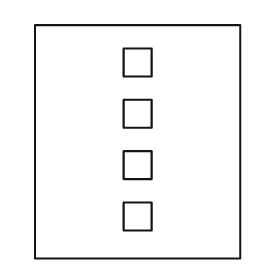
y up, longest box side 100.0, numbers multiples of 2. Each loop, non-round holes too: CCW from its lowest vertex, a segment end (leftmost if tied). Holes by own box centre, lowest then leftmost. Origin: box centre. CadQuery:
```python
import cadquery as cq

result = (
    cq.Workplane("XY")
    .moveTo(-44.0, -50.0)
    .lineTo(44.0, -50.0)
    .lineTo(44.0, 50.0)
    .lineTo(-44.0, 50.0)
    .close()
    .moveTo(-6.0, -38.0)
    .lineTo(6.0, -38.0)
    .lineTo(6.0, -26.0)
    .lineTo(-6.0, -26.0)
    .close()
    .moveTo(-6.0, -16.0)
    .lineTo(6.0, -16.0)
    .lineTo(6.0, -4.0)
    .lineTo(-6.0, -4.0)
    .close()
    .moveTo(-6.0, 6.0)
    .lineTo(6.0, 6.0)
    .lineTo(6.0, 18.0)
    .lineTo(-6.0, 18.0)
    .close()
    .moveTo(-6.0, 28.0)
    .lineTo(6.0, 28.0)
    .lineTo(6.0, 40.0)
    .lineTo(-6.0, 40.0)
    .close()
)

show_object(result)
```